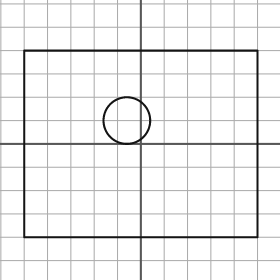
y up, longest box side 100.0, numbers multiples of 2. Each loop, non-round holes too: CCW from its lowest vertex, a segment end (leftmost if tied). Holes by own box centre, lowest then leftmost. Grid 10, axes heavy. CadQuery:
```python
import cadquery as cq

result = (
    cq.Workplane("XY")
    .moveTo(-50.0, -40.0)
    .lineTo(50.0, -40.0)
    .lineTo(50.0, 40.0)
    .lineTo(-50.0, 40.0)
    .close()
    .moveTo(-6.0, 10.0)
    .circle(10.0)
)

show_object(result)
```